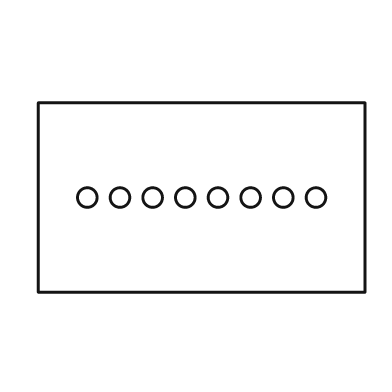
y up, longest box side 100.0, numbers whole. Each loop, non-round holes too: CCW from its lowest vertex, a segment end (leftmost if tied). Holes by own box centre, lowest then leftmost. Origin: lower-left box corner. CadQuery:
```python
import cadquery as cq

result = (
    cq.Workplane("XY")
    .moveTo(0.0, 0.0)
    .lineTo(100.0, 0.0)
    .lineTo(100.0, 58.0)
    .lineTo(0.0, 58.0)
    .close()
    .moveTo(15.0, 29.0)
    .circle(3.0)
    .moveTo(25.0, 29.0)
    .circle(3.0)
    .moveTo(35.0, 29.0)
    .circle(3.0)
    .moveTo(45.0, 29.0)
    .circle(3.0)
    .moveTo(55.0, 29.0)
    .circle(3.0)
    .moveTo(65.0, 29.0)
    .circle(3.0)
    .moveTo(75.0, 29.0)
    .circle(3.0)
    .moveTo(85.0, 29.0)
    .circle(3.0)
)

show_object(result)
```